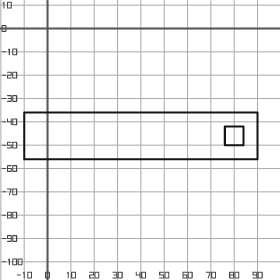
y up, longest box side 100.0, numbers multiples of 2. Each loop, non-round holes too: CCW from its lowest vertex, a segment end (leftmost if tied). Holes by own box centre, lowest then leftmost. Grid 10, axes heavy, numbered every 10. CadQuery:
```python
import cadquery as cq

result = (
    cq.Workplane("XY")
    .moveTo(-10.0, -56.0)
    .lineTo(90.0, -56.0)
    .lineTo(90.0, -36.0)
    .lineTo(-10.0, -36.0)
    .close()
    .moveTo(76.0, -50.0)
    .lineTo(84.0, -50.0)
    .lineTo(84.0, -42.0)
    .lineTo(76.0, -42.0)
    .close()
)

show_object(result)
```